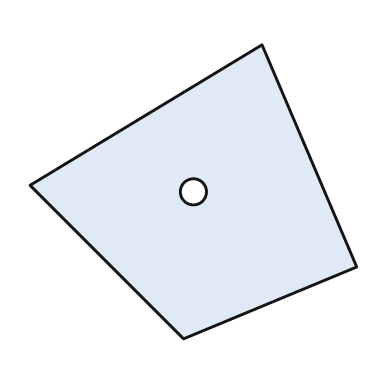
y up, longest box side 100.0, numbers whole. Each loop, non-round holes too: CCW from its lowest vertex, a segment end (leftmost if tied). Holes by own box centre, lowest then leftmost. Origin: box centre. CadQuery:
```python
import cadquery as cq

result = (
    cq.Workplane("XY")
    .moveTo(-3.0, -45.0)
    .lineTo(50.0, -23.0)
    .lineTo(21.0, 45.0)
    .lineTo(-50.0, 2.0)
    .close()
    .moveTo(0.0, 0.0)
    .circle(4.0)
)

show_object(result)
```